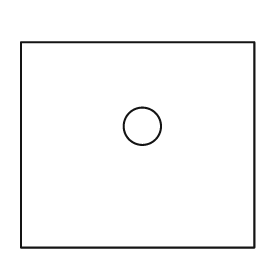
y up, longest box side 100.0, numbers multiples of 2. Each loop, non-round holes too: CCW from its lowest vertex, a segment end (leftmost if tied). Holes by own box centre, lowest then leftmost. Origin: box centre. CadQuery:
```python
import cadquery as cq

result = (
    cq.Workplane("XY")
    .moveTo(-50.0, -44.0)
    .lineTo(50.0, -44.0)
    .lineTo(50.0, 44.0)
    .lineTo(-50.0, 44.0)
    .close()
    .moveTo(2.0, 8.0)
    .circle(8.0)
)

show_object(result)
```